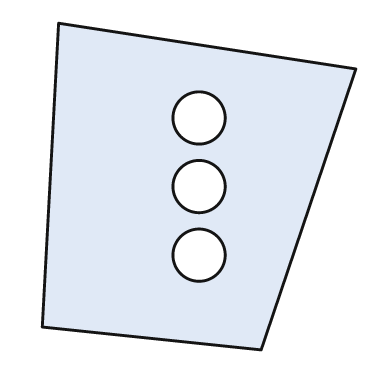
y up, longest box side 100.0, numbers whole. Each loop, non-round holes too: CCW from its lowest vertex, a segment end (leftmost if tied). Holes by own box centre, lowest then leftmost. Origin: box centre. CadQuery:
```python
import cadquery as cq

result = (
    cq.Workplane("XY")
    .moveTo(19.0, -50.0)
    .lineTo(48.0, 36.0)
    .lineTo(-43.0, 50.0)
    .lineTo(-48.0, -43.0)
    .close()
    .moveTo(0.0, -21.0)
    .circle(8.0)
    .moveTo(0.0, 0.0)
    .circle(8.0)
    .moveTo(0.0, 21.0)
    .circle(8.0)
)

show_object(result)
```